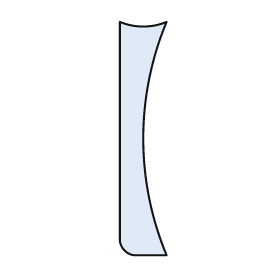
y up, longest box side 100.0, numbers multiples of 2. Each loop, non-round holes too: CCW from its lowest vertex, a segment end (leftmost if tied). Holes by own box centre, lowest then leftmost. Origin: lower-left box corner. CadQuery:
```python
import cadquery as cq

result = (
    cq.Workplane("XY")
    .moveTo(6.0, 0.0)
    .lineTo(20.0, 0.0)
    .threePointArc((10.0, 50.0), (20.0, 100.0))
    .threePointArc((10.0, 98.0), (0.0, 100.0))
    .lineTo(0.0, 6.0)
    .threePointArc((2.0, 2.0), (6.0, 0.0))
    .close()
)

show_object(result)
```